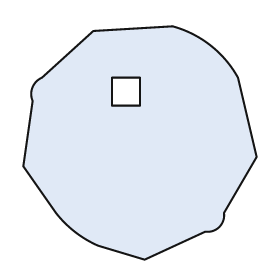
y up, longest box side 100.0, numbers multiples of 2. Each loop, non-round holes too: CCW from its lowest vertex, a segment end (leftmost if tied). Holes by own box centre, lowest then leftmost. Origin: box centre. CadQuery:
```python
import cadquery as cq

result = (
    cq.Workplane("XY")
    .moveTo(2.0, -50.0)
    .lineTo(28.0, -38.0)
    .threePointArc((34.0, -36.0), (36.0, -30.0))
    .lineTo(50.0, -6.0)
    .lineTo(42.0, 28.0)
    .threePointArc((30.0, 42.0), (14.0, 50.0))
    .lineTo(-20.0, 48.0)
    .lineTo(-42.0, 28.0)
    .threePointArc((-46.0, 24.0), (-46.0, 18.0))
    .lineTo(-50.0, -10.0)
    .lineTo(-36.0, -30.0)
    .threePointArc((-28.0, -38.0), (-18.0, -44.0))
    .close()
    .moveTo(-12.0, 16.0)
    .lineTo(0.0, 16.0)
    .lineTo(0.0, 28.0)
    .lineTo(-12.0, 28.0)
    .close()
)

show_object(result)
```